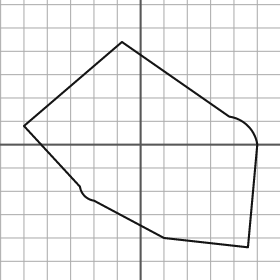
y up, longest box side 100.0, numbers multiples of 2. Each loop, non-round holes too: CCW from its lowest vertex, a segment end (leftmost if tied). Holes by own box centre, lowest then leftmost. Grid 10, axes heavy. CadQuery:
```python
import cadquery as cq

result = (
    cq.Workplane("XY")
    .moveTo(46.0, -44.0)
    .lineTo(50.0, 0.0)
    .threePointArc((46.0, 8.0), (38.0, 12.0))
    .lineTo(-8.0, 44.0)
    .lineTo(-50.0, 8.0)
    .lineTo(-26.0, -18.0)
    .threePointArc((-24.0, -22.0), (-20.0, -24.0))
    .lineTo(10.0, -40.0)
    .close()
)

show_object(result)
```